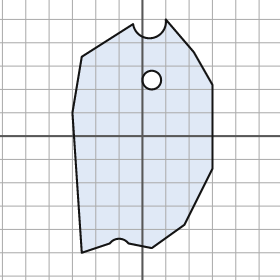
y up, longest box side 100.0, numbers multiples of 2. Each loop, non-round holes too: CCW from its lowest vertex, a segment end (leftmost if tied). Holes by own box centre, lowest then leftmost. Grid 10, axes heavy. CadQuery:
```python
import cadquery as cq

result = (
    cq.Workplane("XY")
    .moveTo(-26.0, -50.0)
    .lineTo(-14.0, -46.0)
    .threePointArc((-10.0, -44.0), (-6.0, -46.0))
    .lineTo(4.0, -48.0)
    .lineTo(18.0, -38.0)
    .lineTo(30.0, -14.0)
    .lineTo(30.0, 22.0)
    .lineTo(22.0, 36.0)
    .lineTo(10.0, 50.0)
    .threePointArc((4.0, 42.0), (-4.0, 48.0))
    .lineTo(-26.0, 34.0)
    .lineTo(-30.0, 10.0)
    .close()
    .moveTo(4.0, 24.0)
    .circle(4.0)
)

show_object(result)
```